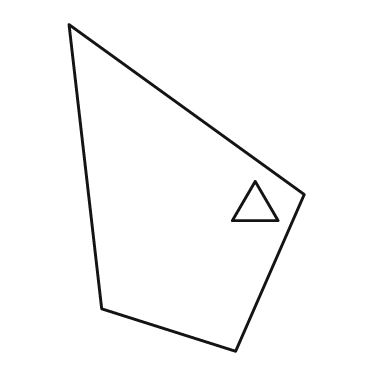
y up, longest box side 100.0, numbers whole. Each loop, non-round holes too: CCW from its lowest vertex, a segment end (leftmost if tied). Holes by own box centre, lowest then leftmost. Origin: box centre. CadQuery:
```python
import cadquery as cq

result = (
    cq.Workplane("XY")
    .moveTo(15.0, -50.0)
    .lineTo(36.0, -2.0)
    .lineTo(-36.0, 50.0)
    .lineTo(-26.0, -37.0)
    .close()
    .moveTo(14.0, -10.0)
    .lineTo(28.0, -10.0)
    .lineTo(21.0, 2.0)
    .close()
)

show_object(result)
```